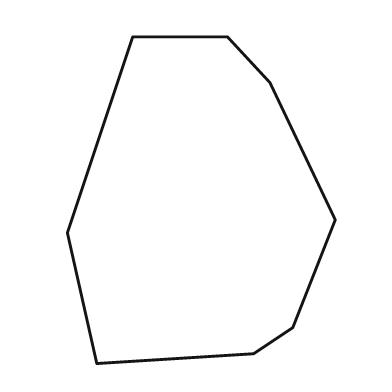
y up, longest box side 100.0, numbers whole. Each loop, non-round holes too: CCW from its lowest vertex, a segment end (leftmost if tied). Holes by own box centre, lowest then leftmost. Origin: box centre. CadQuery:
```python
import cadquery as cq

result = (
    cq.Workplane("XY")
    .moveTo(-32.0, -50.0)
    .lineTo(16.0, -47.0)
    .lineTo(28.0, -39.0)
    .lineTo(41.0, -6.0)
    .lineTo(21.0, 36.0)
    .lineTo(8.0, 50.0)
    .lineTo(-21.0, 50.0)
    .lineTo(-41.0, -10.0)
    .close()
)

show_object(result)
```